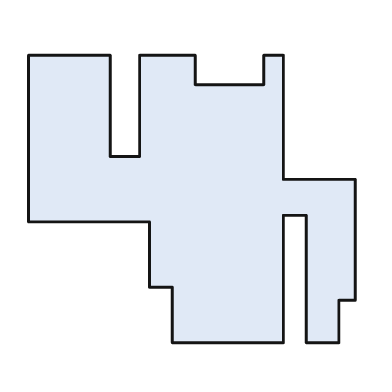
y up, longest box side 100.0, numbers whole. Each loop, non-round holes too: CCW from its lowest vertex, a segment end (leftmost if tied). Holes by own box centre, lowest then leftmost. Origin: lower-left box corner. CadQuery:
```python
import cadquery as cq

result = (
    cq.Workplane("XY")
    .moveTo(44.0, 0.0)
    .lineTo(78.0, 0.0)
    .lineTo(78.0, 39.0)
    .lineTo(85.0, 39.0)
    .lineTo(85.0, 0.0)
    .lineTo(95.0, 0.0)
    .lineTo(95.0, 13.0)
    .lineTo(100.0, 13.0)
    .lineTo(100.0, 50.0)
    .lineTo(78.0, 50.0)
    .lineTo(78.0, 88.0)
    .lineTo(72.0, 88.0)
    .lineTo(72.0, 79.0)
    .lineTo(51.0, 79.0)
    .lineTo(51.0, 88.0)
    .lineTo(34.0, 88.0)
    .lineTo(34.0, 57.0)
    .lineTo(25.0, 57.0)
    .lineTo(25.0, 88.0)
    .lineTo(0.0, 88.0)
    .lineTo(0.0, 37.0)
    .lineTo(37.0, 37.0)
    .lineTo(37.0, 17.0)
    .lineTo(44.0, 17.0)
    .close()
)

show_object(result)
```